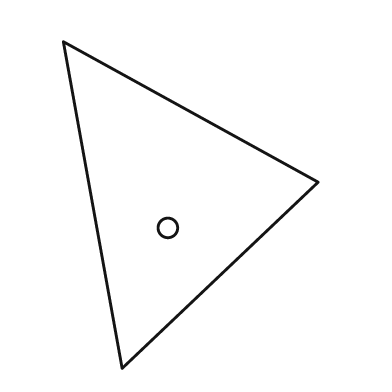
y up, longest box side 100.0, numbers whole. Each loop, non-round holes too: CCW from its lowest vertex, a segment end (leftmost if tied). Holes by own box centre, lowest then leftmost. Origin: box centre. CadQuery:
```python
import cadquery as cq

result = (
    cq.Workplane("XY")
    .moveTo(-21.0, -50.0)
    .lineTo(39.0, 7.0)
    .lineTo(-39.0, 50.0)
    .close()
    .moveTo(-7.0, -7.0)
    .circle(3.0)
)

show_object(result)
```